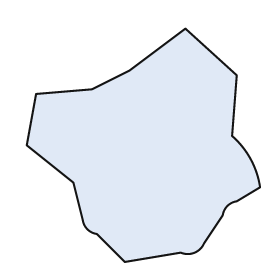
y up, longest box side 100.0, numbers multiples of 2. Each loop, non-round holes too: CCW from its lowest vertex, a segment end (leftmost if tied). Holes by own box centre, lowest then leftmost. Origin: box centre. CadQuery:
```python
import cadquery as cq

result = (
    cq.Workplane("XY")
    .moveTo(-8.0, -50.0)
    .lineTo(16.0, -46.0)
    .threePointArc((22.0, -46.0), (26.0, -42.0))
    .lineTo(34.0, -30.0)
    .threePointArc((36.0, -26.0), (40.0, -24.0))
    .lineTo(50.0, -18.0)
    .threePointArc((46.0, -6.0), (38.0, 4.0))
    .lineTo(40.0, 30.0)
    .lineTo(18.0, 50.0)
    .lineTo(-6.0, 32.0)
    .lineTo(-22.0, 24.0)
    .lineTo(-46.0, 22.0)
    .lineTo(-50.0, 0.0)
    .lineTo(-30.0, -16.0)
    .lineTo(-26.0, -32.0)
    .threePointArc((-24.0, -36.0), (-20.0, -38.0))
    .close()
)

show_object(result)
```